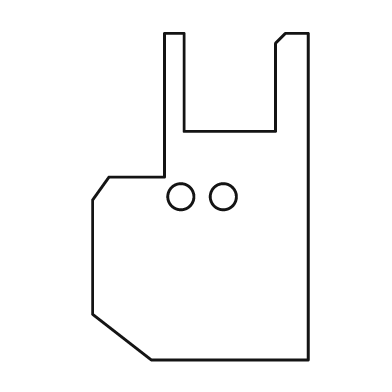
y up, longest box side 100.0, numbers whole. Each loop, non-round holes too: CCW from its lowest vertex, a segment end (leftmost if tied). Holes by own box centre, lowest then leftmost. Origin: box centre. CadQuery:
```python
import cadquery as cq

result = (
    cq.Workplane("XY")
    .moveTo(-15.0, -50.0)
    .lineTo(33.0, -50.0)
    .lineTo(33.0, 50.0)
    .lineTo(26.0, 50.0)
    .lineTo(23.0, 47.0)
    .lineTo(23.0, 20.0)
    .lineTo(-5.0, 20.0)
    .lineTo(-5.0, 50.0)
    .lineTo(-11.0, 50.0)
    .lineTo(-11.0, 6.0)
    .lineTo(-28.0, 6.0)
    .lineTo(-33.0, -1.0)
    .lineTo(-33.0, -36.0)
    .close()
    .moveTo(-6.0, 0.0)
    .circle(4.0)
    .moveTo(7.0, 0.0)
    .circle(4.0)
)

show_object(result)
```